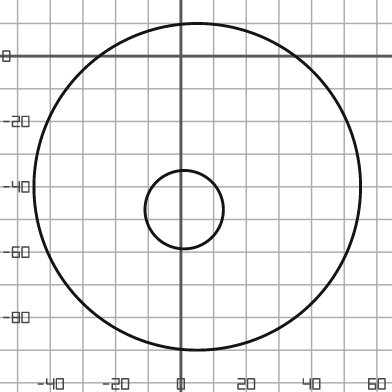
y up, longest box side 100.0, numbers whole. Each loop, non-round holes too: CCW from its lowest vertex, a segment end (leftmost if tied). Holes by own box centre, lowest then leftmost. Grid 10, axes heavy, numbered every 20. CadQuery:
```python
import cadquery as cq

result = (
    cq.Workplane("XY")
    .moveTo(5.0, -40.0)
    .circle(50.0)
    .moveTo(1.0, -47.0)
    .circle(12.0)
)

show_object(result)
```